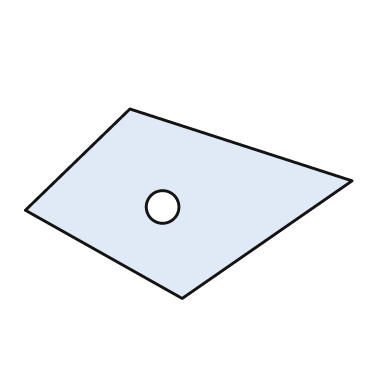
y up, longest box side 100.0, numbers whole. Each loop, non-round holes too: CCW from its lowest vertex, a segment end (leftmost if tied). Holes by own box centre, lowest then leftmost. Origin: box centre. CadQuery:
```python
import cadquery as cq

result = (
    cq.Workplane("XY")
    .moveTo(-2.0, -29.0)
    .lineTo(50.0, 7.0)
    .lineTo(-18.0, 29.0)
    .lineTo(-50.0, -2.0)
    .close()
    .moveTo(-8.0, -1.0)
    .circle(5.0)
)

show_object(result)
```